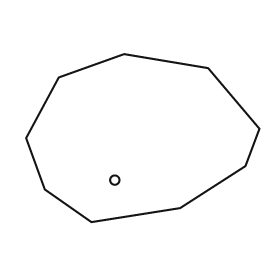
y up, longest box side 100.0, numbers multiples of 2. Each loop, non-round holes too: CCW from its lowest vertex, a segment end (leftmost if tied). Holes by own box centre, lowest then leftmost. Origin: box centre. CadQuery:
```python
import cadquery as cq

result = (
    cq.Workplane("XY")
    .moveTo(-22.0, -36.0)
    .lineTo(16.0, -30.0)
    .lineTo(44.0, -12.0)
    .lineTo(50.0, 4.0)
    .lineTo(28.0, 30.0)
    .lineTo(-8.0, 36.0)
    .lineTo(-36.0, 26.0)
    .lineTo(-50.0, 0.0)
    .lineTo(-42.0, -22.0)
    .close()
    .moveTo(-12.0, -18.0)
    .circle(2.0)
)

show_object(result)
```